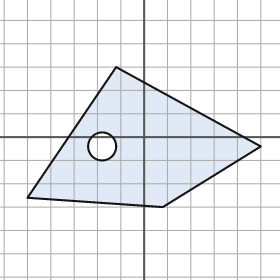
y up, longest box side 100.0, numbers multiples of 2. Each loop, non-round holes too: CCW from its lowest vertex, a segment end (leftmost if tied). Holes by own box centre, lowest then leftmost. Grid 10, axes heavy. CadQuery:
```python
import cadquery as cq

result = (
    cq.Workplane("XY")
    .moveTo(8.0, -30.0)
    .lineTo(50.0, -4.0)
    .lineTo(-12.0, 30.0)
    .lineTo(-50.0, -26.0)
    .close()
    .moveTo(-18.0, -4.0)
    .circle(6.0)
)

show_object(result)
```